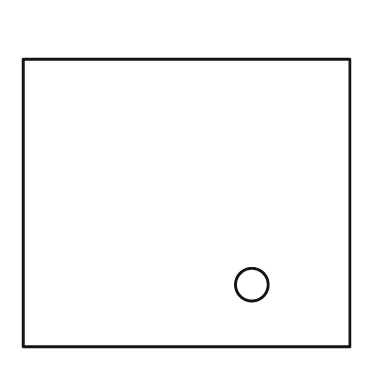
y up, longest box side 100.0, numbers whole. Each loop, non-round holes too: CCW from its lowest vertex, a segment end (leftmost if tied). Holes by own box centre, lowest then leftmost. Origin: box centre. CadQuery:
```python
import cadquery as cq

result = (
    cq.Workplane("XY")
    .moveTo(-50.0, -44.0)
    .lineTo(50.0, -44.0)
    .lineTo(50.0, 44.0)
    .lineTo(-50.0, 44.0)
    .close()
    .moveTo(20.0, -25.0)
    .circle(5.0)
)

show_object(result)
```